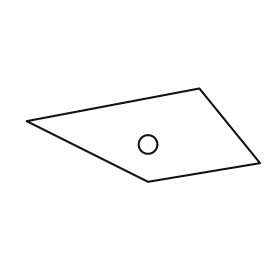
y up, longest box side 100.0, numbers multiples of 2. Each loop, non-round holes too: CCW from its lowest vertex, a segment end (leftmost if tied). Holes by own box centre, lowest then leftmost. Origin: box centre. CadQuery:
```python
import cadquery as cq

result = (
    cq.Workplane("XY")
    .moveTo(2.0, -20.0)
    .lineTo(50.0, -12.0)
    .lineTo(24.0, 20.0)
    .lineTo(-50.0, 6.0)
    .close()
    .moveTo(2.0, -4.0)
    .circle(4.0)
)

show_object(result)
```